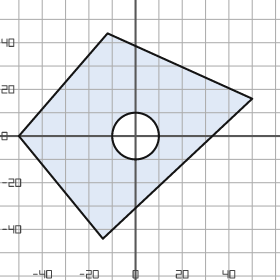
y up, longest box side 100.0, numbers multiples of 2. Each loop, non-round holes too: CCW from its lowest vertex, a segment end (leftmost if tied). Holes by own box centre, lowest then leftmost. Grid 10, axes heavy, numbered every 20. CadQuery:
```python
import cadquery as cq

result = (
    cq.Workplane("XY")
    .moveTo(-14.0, -44.0)
    .lineTo(50.0, 16.0)
    .lineTo(-12.0, 44.0)
    .lineTo(-50.0, 0.0)
    .close()
    .moveTo(0.0, 0.0)
    .circle(10.0)
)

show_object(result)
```